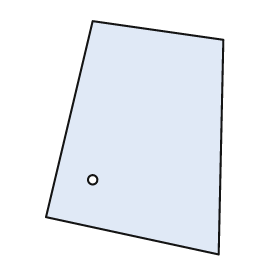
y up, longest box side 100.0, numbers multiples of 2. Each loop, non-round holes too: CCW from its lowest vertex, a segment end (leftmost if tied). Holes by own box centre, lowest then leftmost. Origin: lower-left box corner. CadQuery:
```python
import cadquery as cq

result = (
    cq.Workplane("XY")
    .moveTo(74.0, 0.0)
    .lineTo(76.0, 92.0)
    .lineTo(20.0, 100.0)
    .lineTo(0.0, 16.0)
    .close()
    .moveTo(20.0, 32.0)
    .circle(2.0)
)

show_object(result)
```